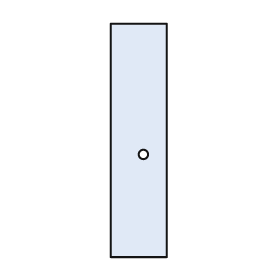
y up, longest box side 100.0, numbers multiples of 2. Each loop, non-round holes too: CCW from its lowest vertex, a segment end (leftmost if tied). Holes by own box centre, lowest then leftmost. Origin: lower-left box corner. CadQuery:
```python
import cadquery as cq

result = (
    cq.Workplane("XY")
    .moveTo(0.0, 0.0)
    .lineTo(24.0, 0.0)
    .lineTo(24.0, 100.0)
    .lineTo(0.0, 100.0)
    .close()
    .moveTo(14.0, 44.0)
    .circle(2.0)
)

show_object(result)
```